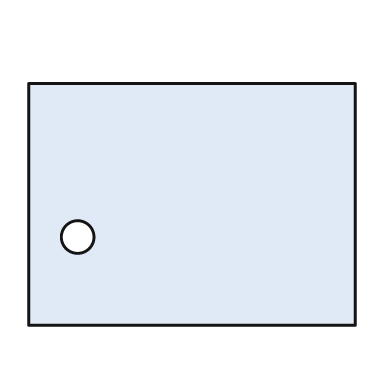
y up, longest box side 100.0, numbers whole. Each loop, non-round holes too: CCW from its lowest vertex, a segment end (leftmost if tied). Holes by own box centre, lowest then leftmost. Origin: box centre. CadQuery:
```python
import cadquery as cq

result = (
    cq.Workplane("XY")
    .moveTo(-50.0, -37.0)
    .lineTo(50.0, -37.0)
    .lineTo(50.0, 37.0)
    .lineTo(-50.0, 37.0)
    .close()
    .moveTo(-35.0, -10.0)
    .circle(5.0)
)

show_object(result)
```